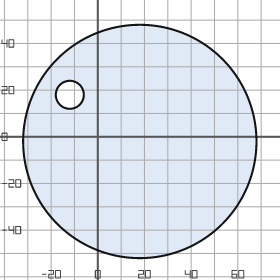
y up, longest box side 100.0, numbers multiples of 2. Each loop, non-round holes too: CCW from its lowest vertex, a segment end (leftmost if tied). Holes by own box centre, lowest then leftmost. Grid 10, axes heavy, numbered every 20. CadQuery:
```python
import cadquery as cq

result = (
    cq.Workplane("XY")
    .moveTo(18.0, -2.0)
    .circle(50.0)
    .moveTo(-12.0, 18.0)
    .circle(6.0)
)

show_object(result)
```